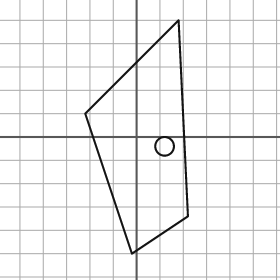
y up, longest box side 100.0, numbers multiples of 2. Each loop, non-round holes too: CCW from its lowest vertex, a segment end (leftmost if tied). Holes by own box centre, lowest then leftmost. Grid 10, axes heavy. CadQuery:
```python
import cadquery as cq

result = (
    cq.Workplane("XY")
    .moveTo(-2.0, -50.0)
    .lineTo(22.0, -34.0)
    .lineTo(18.0, 50.0)
    .lineTo(-22.0, 10.0)
    .close()
    .moveTo(12.0, -4.0)
    .circle(4.0)
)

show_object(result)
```